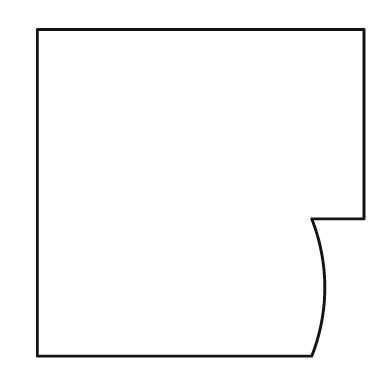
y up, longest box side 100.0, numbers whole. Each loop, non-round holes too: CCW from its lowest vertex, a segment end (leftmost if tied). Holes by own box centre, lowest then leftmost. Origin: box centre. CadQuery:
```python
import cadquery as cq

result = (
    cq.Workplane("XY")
    .moveTo(-50.0, -50.0)
    .lineTo(34.0, -50.0)
    .threePointArc((38.0, -29.0), (34.0, -8.0))
    .lineTo(50.0, -8.0)
    .lineTo(50.0, 50.0)
    .lineTo(-50.0, 50.0)
    .close()
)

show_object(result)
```